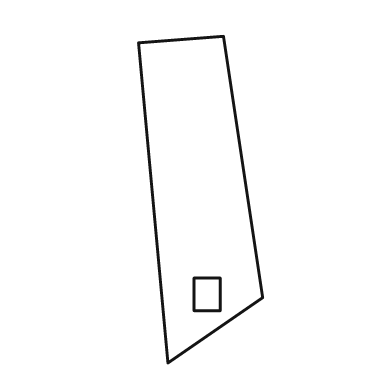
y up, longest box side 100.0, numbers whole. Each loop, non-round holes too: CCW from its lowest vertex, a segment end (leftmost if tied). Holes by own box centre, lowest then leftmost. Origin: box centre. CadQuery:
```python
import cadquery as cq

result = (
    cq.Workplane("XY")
    .moveTo(-10.0, -50.0)
    .lineTo(19.0, -30.0)
    .lineTo(7.0, 50.0)
    .lineTo(-19.0, 48.0)
    .close()
    .moveTo(-2.0, -34.0)
    .lineTo(6.0, -34.0)
    .lineTo(6.0, -24.0)
    .lineTo(-2.0, -24.0)
    .close()
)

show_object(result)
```